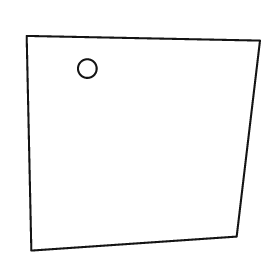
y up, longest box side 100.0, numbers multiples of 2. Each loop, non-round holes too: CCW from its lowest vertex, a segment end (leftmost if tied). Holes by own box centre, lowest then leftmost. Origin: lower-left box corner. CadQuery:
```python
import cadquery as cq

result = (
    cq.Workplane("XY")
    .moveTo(2.0, 0.0)
    .lineTo(90.0, 6.0)
    .lineTo(100.0, 90.0)
    .lineTo(0.0, 92.0)
    .close()
    .moveTo(26.0, 78.0)
    .circle(4.0)
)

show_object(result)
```